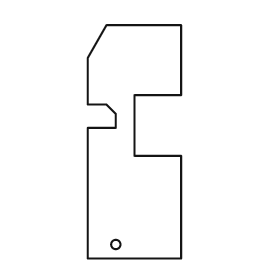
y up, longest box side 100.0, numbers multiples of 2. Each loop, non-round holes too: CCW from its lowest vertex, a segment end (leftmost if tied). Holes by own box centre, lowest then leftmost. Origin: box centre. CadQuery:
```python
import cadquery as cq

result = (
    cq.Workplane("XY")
    .moveTo(-20.0, -50.0)
    .lineTo(20.0, -50.0)
    .lineTo(20.0, -6.0)
    .lineTo(0.0, -6.0)
    .lineTo(0.0, 20.0)
    .lineTo(20.0, 20.0)
    .lineTo(20.0, 50.0)
    .lineTo(-12.0, 50.0)
    .lineTo(-20.0, 36.0)
    .lineTo(-20.0, 16.0)
    .lineTo(-12.0, 16.0)
    .lineTo(-8.0, 12.0)
    .lineTo(-8.0, 6.0)
    .lineTo(-20.0, 6.0)
    .close()
    .moveTo(-8.0, -44.0)
    .circle(2.0)
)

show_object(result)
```